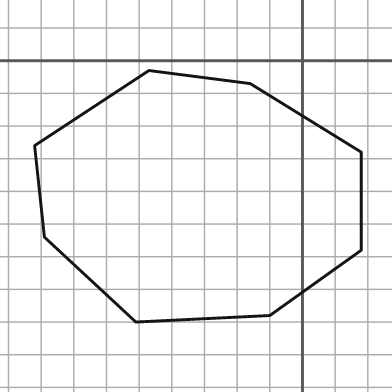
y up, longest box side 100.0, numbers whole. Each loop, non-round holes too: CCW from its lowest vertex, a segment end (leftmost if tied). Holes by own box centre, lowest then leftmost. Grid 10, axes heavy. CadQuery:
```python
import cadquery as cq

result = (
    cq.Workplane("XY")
    .moveTo(-51.0, -80.0)
    .lineTo(-10.0, -78.0)
    .lineTo(18.0, -58.0)
    .lineTo(18.0, -28.0)
    .lineTo(-16.0, -7.0)
    .lineTo(-47.0, -3.0)
    .lineTo(-82.0, -26.0)
    .lineTo(-79.0, -54.0)
    .close()
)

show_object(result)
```